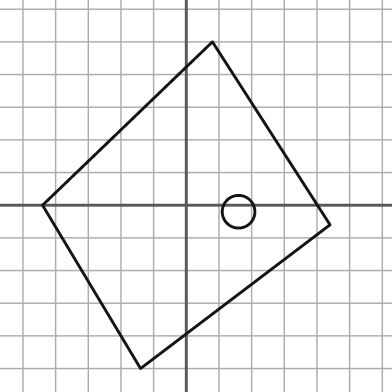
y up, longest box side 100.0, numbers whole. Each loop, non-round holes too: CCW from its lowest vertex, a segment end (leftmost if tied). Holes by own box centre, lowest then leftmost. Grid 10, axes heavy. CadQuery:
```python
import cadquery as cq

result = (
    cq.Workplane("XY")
    .moveTo(-14.0, -50.0)
    .lineTo(44.0, -6.0)
    .lineTo(8.0, 50.0)
    .lineTo(-44.0, 0.0)
    .close()
    .moveTo(16.0, -2.0)
    .circle(5.0)
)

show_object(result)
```